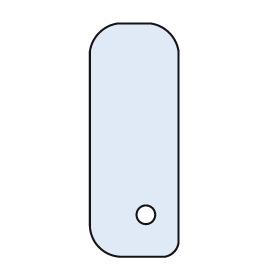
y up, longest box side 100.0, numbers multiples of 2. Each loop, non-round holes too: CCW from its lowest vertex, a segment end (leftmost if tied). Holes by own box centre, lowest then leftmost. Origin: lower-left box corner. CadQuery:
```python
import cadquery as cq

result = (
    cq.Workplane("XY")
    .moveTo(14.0, 0.0)
    .lineTo(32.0, 0.0)
    .threePointArc((36.0, 2.0), (38.0, 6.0))
    .lineTo(38.0, 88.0)
    .threePointArc((34.0, 96.0), (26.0, 100.0))
    .lineTo(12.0, 100.0)
    .threePointArc((4.0, 96.0), (0.0, 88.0))
    .lineTo(0.0, 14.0)
    .threePointArc((4.0, 4.0), (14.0, 0.0))
    .close()
    .moveTo(24.0, 18.0)
    .circle(4.0)
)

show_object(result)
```